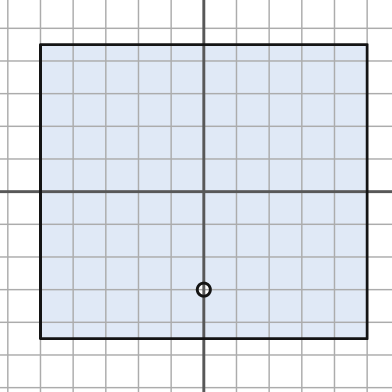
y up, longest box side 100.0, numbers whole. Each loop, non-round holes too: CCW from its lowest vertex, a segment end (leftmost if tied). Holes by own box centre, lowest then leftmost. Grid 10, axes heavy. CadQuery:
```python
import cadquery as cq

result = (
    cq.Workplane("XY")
    .moveTo(-50.0, -45.0)
    .lineTo(50.0, -45.0)
    .lineTo(50.0, 45.0)
    .lineTo(-50.0, 45.0)
    .close()
    .moveTo(0.0, -30.0)
    .circle(2.0)
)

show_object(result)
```